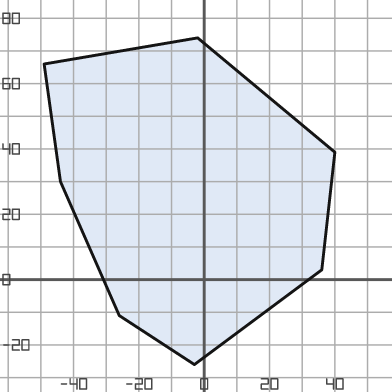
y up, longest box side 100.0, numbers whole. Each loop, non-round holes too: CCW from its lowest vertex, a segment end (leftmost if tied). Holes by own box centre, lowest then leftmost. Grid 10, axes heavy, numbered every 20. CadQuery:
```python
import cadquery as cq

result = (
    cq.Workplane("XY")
    .moveTo(-3.0, -26.0)
    .lineTo(36.0, 3.0)
    .lineTo(40.0, 39.0)
    .lineTo(-2.0, 74.0)
    .lineTo(-49.0, 66.0)
    .lineTo(-44.0, 30.0)
    .lineTo(-26.0, -11.0)
    .close()
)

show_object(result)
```